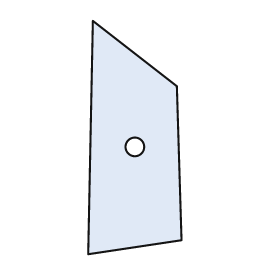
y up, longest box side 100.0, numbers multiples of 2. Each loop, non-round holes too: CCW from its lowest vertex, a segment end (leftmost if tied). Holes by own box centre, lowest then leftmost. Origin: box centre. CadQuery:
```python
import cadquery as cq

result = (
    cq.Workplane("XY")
    .moveTo(-20.0, -50.0)
    .lineTo(20.0, -44.0)
    .lineTo(18.0, 22.0)
    .lineTo(-18.0, 50.0)
    .close()
    .moveTo(0.0, -4.0)
    .circle(4.0)
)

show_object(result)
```